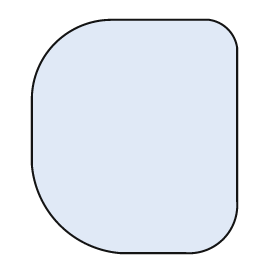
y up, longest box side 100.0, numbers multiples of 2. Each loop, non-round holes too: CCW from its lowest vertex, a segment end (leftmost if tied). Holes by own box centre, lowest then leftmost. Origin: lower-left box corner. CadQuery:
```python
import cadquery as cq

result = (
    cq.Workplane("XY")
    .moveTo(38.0, 0.0)
    .lineTo(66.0, 0.0)
    .threePointArc((82.0, 6.0), (88.0, 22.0))
    .lineTo(88.0, 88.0)
    .threePointArc((84.0, 96.0), (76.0, 100.0))
    .lineTo(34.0, 100.0)
    .threePointArc((10.0, 90.0), (0.0, 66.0))
    .lineTo(0.0, 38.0)
    .threePointArc((12.0, 12.0), (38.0, 0.0))
    .close()
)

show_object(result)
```